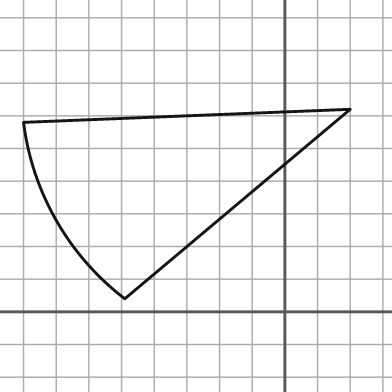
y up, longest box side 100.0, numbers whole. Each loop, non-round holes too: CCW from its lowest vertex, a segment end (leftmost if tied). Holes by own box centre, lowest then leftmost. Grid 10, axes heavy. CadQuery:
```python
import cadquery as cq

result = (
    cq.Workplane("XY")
    .moveTo(-49.0, 4.0)
    .lineTo(20.0, 62.0)
    .lineTo(-80.0, 58.0)
    .threePointArc((-70.0, 28.0), (-49.0, 4.0))
    .close()
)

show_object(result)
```